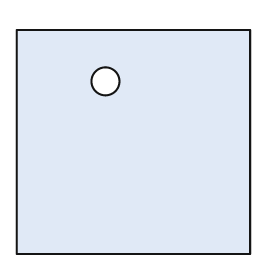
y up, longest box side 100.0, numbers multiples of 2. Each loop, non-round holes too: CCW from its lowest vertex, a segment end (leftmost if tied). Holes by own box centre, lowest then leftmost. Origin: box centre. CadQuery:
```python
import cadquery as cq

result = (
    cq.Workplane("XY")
    .moveTo(-50.0, -48.0)
    .lineTo(50.0, -48.0)
    .lineTo(50.0, 48.0)
    .lineTo(-50.0, 48.0)
    .close()
    .moveTo(-12.0, 26.0)
    .circle(6.0)
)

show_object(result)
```